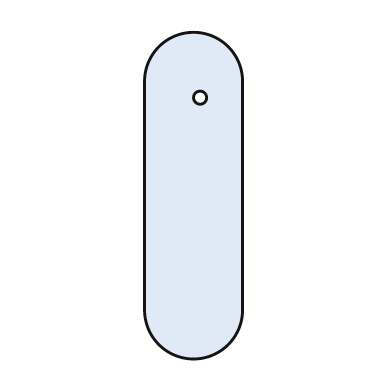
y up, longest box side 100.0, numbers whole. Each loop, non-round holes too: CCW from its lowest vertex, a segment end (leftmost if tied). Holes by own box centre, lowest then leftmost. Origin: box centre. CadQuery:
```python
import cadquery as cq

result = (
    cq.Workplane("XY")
    .moveTo(-15.0, -35.0)
    .threePointArc((0.0, -50.0), (15.0, -35.0))
    .lineTo(15.0, 35.0)
    .threePointArc((0.0, 50.0), (-15.0, 35.0))
    .close()
    .moveTo(2.0, 30.0)
    .circle(2.0)
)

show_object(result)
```